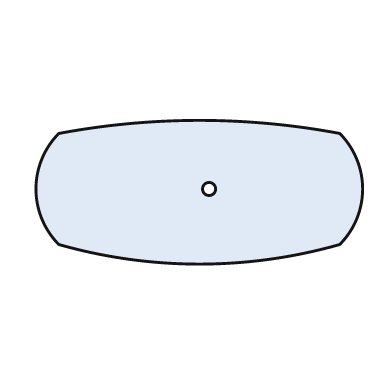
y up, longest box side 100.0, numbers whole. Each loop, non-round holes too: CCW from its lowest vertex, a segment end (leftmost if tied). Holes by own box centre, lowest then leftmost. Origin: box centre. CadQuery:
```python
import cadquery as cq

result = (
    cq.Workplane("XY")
    .moveTo(-43.0, -16.0)
    .threePointArc((0.0, -22.0), (43.0, -16.0))
    .threePointArc((50.0, 1.0), (43.0, 18.0))
    .threePointArc((0.0, 22.0), (-43.0, 18.0))
    .threePointArc((-50.0, 1.0), (-43.0, -16.0))
    .close()
    .moveTo(3.0, 1.0)
    .circle(2.0)
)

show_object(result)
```